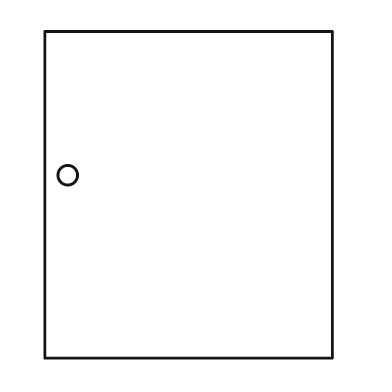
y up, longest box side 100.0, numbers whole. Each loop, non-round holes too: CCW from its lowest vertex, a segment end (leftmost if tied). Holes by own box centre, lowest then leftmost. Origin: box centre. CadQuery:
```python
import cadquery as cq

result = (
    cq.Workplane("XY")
    .moveTo(-44.0, -50.0)
    .lineTo(44.0, -50.0)
    .lineTo(44.0, 50.0)
    .lineTo(-44.0, 50.0)
    .close()
    .moveTo(-37.0, 6.0)
    .circle(3.0)
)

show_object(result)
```